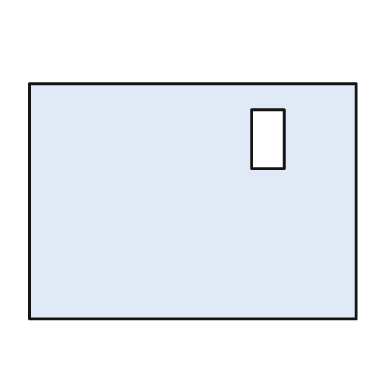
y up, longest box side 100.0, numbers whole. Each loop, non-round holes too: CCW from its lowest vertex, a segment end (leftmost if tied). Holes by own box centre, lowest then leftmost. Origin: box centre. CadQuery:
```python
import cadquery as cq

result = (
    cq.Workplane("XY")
    .moveTo(-50.0, -36.0)
    .lineTo(50.0, -36.0)
    .lineTo(50.0, 36.0)
    .lineTo(-50.0, 36.0)
    .close()
    .moveTo(18.0, 10.0)
    .lineTo(28.0, 10.0)
    .lineTo(28.0, 28.0)
    .lineTo(18.0, 28.0)
    .close()
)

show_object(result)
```